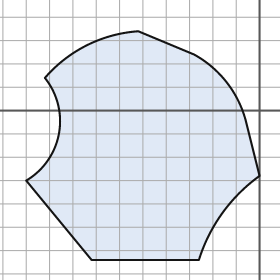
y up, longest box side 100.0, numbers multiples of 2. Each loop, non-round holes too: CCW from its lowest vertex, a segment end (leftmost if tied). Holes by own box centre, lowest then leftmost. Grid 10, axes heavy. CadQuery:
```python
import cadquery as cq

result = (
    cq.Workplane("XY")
    .moveTo(-72.0, -64.0)
    .lineTo(-26.0, -64.0)
    .threePointArc((-16.0, -44.0), (0.0, -28.0))
    .lineTo(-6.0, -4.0)
    .threePointArc((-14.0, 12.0), (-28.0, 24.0))
    .lineTo(-52.0, 34.0)
    .threePointArc((-74.0, 28.0), (-92.0, 14.0))
    .threePointArc((-86.0, -10.0), (-100.0, -30.0))
    .close()
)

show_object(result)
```